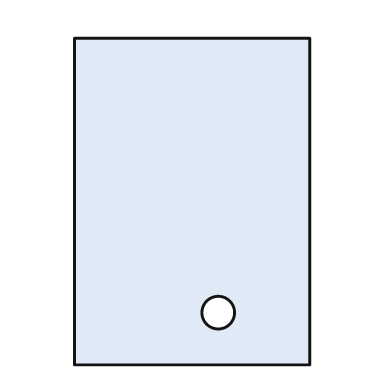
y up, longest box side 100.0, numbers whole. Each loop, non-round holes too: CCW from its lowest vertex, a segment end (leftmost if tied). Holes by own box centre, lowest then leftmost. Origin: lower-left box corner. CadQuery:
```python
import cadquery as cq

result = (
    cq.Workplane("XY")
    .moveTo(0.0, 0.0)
    .lineTo(72.0, 0.0)
    .lineTo(72.0, 100.0)
    .lineTo(0.0, 100.0)
    .close()
    .moveTo(44.0, 16.0)
    .circle(5.0)
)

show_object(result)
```